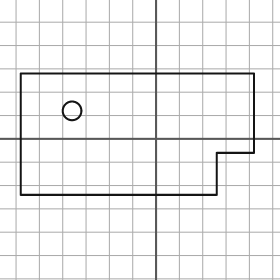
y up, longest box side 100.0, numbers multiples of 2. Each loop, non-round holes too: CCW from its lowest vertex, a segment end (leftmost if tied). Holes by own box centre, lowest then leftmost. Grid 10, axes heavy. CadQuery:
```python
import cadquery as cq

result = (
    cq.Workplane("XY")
    .moveTo(-58.0, -24.0)
    .lineTo(26.0, -24.0)
    .lineTo(26.0, -6.0)
    .lineTo(42.0, -6.0)
    .lineTo(42.0, 28.0)
    .lineTo(-58.0, 28.0)
    .close()
    .moveTo(-36.0, 12.0)
    .circle(4.0)
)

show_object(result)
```